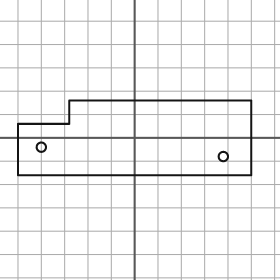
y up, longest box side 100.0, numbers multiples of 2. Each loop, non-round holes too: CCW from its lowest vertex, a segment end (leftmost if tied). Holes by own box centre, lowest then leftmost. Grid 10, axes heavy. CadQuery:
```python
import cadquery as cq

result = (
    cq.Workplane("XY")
    .moveTo(-50.0, -16.0)
    .lineTo(50.0, -16.0)
    .lineTo(50.0, 16.0)
    .lineTo(-28.0, 16.0)
    .lineTo(-28.0, 6.0)
    .lineTo(-50.0, 6.0)
    .close()
    .moveTo(38.0, -8.0)
    .circle(2.0)
    .moveTo(-40.0, -4.0)
    .circle(2.0)
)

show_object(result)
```